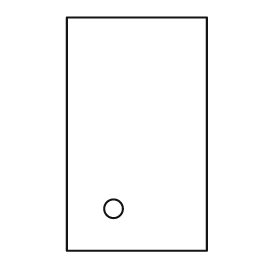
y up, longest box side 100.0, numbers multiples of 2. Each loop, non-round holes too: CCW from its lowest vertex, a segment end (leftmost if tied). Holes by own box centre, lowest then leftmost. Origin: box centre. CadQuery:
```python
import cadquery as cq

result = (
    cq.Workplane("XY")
    .moveTo(-30.0, -50.0)
    .lineTo(30.0, -50.0)
    .lineTo(30.0, 50.0)
    .lineTo(-30.0, 50.0)
    .close()
    .moveTo(-10.0, -32.0)
    .circle(4.0)
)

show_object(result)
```